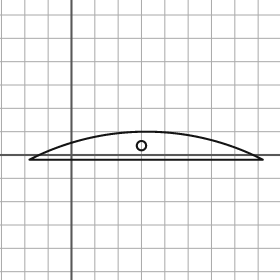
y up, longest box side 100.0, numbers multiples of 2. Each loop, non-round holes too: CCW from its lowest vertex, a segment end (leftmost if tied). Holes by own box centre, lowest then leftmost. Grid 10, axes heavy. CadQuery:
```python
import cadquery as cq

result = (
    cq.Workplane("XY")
    .moveTo(-18.0, -2.0)
    .lineTo(82.0, -2.0)
    .threePointArc((32.0, 10.0), (-18.0, -2.0))
    .close()
    .moveTo(30.0, 4.0)
    .circle(2.0)
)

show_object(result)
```